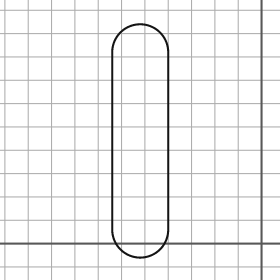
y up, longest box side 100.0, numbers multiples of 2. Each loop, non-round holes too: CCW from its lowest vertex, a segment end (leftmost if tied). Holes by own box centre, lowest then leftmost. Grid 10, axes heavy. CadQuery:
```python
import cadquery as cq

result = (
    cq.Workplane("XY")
    .moveTo(-64.0, 6.0)
    .threePointArc((-52.0, -6.0), (-40.0, 6.0))
    .lineTo(-40.0, 82.0)
    .threePointArc((-52.0, 94.0), (-64.0, 82.0))
    .close()
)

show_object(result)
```